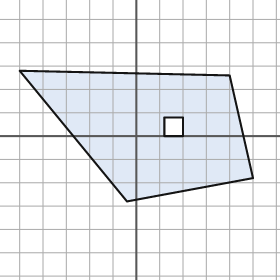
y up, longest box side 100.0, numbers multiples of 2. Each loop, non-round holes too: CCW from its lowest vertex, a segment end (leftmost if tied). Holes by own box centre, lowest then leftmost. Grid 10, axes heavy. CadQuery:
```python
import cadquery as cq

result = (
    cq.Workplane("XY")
    .moveTo(-4.0, -28.0)
    .lineTo(50.0, -18.0)
    .lineTo(40.0, 26.0)
    .lineTo(-50.0, 28.0)
    .close()
    .moveTo(12.0, 0.0)
    .lineTo(20.0, 0.0)
    .lineTo(20.0, 8.0)
    .lineTo(12.0, 8.0)
    .close()
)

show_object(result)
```